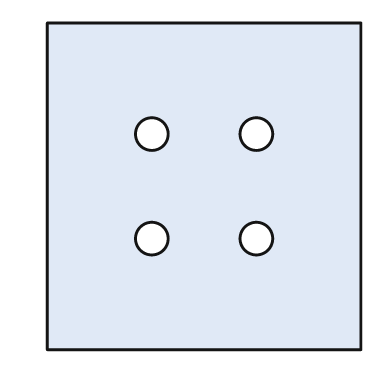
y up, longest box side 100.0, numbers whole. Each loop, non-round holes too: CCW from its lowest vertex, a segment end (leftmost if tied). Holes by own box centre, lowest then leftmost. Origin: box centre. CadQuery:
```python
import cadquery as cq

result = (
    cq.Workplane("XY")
    .moveTo(-48.0, -50.0)
    .lineTo(48.0, -50.0)
    .lineTo(48.0, 50.0)
    .lineTo(-48.0, 50.0)
    .close()
    .moveTo(-16.0, -16.0)
    .circle(5.0)
    .moveTo(16.0, -16.0)
    .circle(5.0)
    .moveTo(-16.0, 16.0)
    .circle(5.0)
    .moveTo(16.0, 16.0)
    .circle(5.0)
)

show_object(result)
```